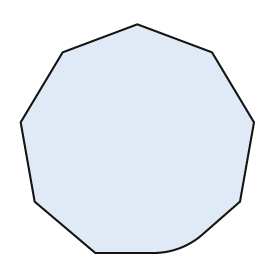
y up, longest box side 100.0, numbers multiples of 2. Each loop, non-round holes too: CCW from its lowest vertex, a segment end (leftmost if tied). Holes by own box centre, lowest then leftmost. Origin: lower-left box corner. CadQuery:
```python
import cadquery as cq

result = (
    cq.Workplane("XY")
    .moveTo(32.0, 0.0)
    .lineTo(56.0, 0.0)
    .threePointArc((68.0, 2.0), (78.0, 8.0))
    .lineTo(94.0, 22.0)
    .lineTo(100.0, 56.0)
    .lineTo(82.0, 86.0)
    .lineTo(50.0, 98.0)
    .lineTo(18.0, 86.0)
    .lineTo(0.0, 56.0)
    .lineTo(6.0, 22.0)
    .close()
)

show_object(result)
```